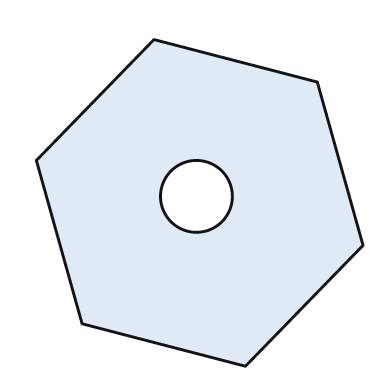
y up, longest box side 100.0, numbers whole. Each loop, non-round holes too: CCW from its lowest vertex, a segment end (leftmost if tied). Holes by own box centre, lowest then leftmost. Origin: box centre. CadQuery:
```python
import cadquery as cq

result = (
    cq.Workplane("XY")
    .moveTo(14.0, -50.0)
    .lineTo(50.0, -13.0)
    .lineTo(36.0, 37.0)
    .lineTo(-14.0, 50.0)
    .lineTo(-50.0, 13.0)
    .lineTo(-36.0, -37.0)
    .close()
    .moveTo(-1.0, 2.0)
    .circle(11.0)
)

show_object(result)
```